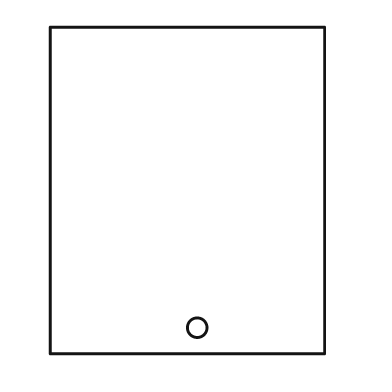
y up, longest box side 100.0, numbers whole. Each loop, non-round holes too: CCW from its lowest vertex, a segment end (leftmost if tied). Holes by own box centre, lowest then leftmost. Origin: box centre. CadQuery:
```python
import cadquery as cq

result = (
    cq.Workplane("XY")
    .moveTo(-42.0, -50.0)
    .lineTo(42.0, -50.0)
    .lineTo(42.0, 50.0)
    .lineTo(-42.0, 50.0)
    .close()
    .moveTo(3.0, -42.0)
    .circle(3.0)
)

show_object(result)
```